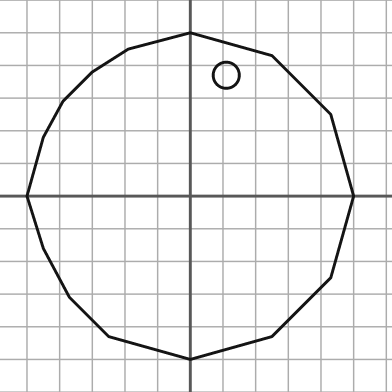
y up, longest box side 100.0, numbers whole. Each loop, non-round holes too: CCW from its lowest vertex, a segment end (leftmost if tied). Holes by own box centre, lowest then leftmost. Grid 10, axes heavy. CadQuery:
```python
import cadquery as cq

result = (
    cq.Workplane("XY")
    .moveTo(0.0, -50.0)
    .lineTo(25.0, -43.0)
    .lineTo(43.0, -25.0)
    .lineTo(50.0, 0.0)
    .lineTo(43.0, 25.0)
    .lineTo(25.0, 43.0)
    .lineTo(0.0, 50.0)
    .lineTo(-19.0, 45.0)
    .lineTo(-30.0, 38.0)
    .lineTo(-39.0, 29.0)
    .lineTo(-45.0, 18.0)
    .lineTo(-50.0, 0.0)
    .lineTo(-45.0, -16.0)
    .lineTo(-37.0, -31.0)
    .lineTo(-25.0, -43.0)
    .close()
    .moveTo(11.0, 37.0)
    .circle(4.0)
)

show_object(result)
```